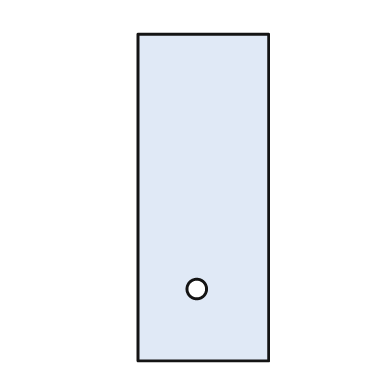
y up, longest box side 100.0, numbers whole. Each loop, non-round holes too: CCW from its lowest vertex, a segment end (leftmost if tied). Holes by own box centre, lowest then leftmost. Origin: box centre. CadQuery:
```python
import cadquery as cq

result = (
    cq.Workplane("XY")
    .moveTo(-20.0, -50.0)
    .lineTo(20.0, -50.0)
    .lineTo(20.0, 50.0)
    .lineTo(-20.0, 50.0)
    .close()
    .moveTo(-2.0, -28.0)
    .circle(3.0)
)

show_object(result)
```